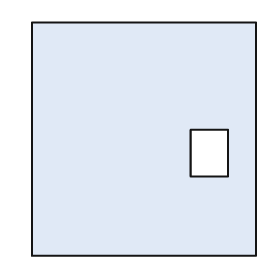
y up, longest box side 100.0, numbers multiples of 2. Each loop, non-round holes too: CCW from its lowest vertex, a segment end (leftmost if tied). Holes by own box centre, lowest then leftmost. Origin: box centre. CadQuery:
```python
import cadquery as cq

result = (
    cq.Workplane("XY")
    .moveTo(-48.0, -50.0)
    .lineTo(48.0, -50.0)
    .lineTo(48.0, 50.0)
    .lineTo(-48.0, 50.0)
    .close()
    .moveTo(20.0, -16.0)
    .lineTo(36.0, -16.0)
    .lineTo(36.0, 4.0)
    .lineTo(20.0, 4.0)
    .close()
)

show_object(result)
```